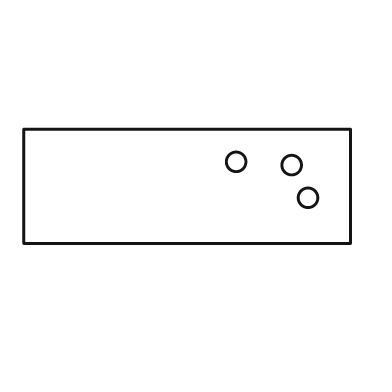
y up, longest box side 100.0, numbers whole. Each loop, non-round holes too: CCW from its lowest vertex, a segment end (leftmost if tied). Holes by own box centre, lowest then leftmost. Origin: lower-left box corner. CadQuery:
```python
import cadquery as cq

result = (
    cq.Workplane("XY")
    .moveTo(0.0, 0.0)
    .lineTo(100.0, 0.0)
    .lineTo(100.0, 35.0)
    .lineTo(0.0, 35.0)
    .close()
    .moveTo(87.0, 14.0)
    .circle(3.0)
    .moveTo(82.0, 24.0)
    .circle(3.0)
    .moveTo(65.0, 25.0)
    .circle(3.0)
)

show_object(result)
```